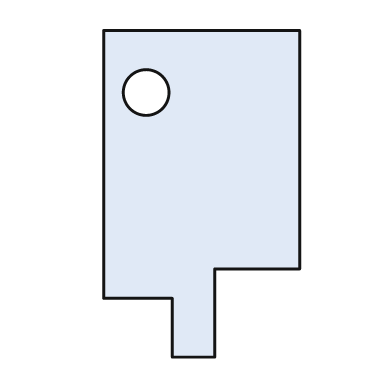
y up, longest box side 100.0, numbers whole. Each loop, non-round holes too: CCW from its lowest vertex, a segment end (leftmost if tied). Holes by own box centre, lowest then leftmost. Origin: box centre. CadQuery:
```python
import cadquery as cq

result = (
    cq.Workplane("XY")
    .moveTo(-9.0, -50.0)
    .lineTo(4.0, -50.0)
    .lineTo(4.0, -23.0)
    .lineTo(30.0, -23.0)
    .lineTo(30.0, 50.0)
    .lineTo(-30.0, 50.0)
    .lineTo(-30.0, -32.0)
    .lineTo(-9.0, -32.0)
    .close()
    .moveTo(-17.0, 31.0)
    .circle(7.0)
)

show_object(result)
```